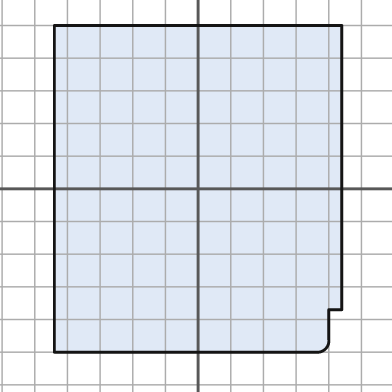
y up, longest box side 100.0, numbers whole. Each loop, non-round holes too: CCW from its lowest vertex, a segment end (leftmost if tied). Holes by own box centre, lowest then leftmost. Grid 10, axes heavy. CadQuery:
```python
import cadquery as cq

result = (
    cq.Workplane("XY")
    .moveTo(-44.0, -50.0)
    .lineTo(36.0, -50.0)
    .threePointArc((39.0, -49.0), (40.0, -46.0))
    .lineTo(40.0, -37.0)
    .lineTo(44.0, -37.0)
    .lineTo(44.0, 50.0)
    .lineTo(-44.0, 50.0)
    .close()
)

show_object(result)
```